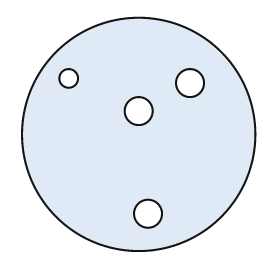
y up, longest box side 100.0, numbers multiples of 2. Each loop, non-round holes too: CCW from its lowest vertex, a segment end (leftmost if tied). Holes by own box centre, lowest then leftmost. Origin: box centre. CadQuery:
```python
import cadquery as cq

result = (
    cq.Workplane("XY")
    .moveTo(0.0, 0.0)
    .circle(50.0)
    .moveTo(4.0, -34.0)
    .circle(6.0)
    .moveTo(0.0, 10.0)
    .circle(6.0)
    .moveTo(22.0, 22.0)
    .circle(6.0)
    .moveTo(-30.0, 24.0)
    .circle(4.0)
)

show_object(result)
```